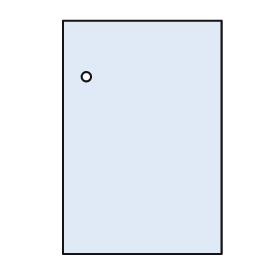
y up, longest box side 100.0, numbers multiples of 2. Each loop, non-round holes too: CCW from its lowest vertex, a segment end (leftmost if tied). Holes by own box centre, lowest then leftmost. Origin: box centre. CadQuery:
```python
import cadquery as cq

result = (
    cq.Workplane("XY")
    .moveTo(-34.0, -50.0)
    .lineTo(34.0, -50.0)
    .lineTo(34.0, 50.0)
    .lineTo(-34.0, 50.0)
    .close()
    .moveTo(-24.0, 26.0)
    .circle(2.0)
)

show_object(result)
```